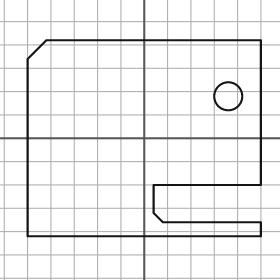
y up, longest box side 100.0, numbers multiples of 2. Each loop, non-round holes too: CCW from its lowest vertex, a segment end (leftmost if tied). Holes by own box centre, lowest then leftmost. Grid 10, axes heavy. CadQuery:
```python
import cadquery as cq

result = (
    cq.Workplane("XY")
    .moveTo(-50.0, -42.0)
    .lineTo(50.0, -42.0)
    .lineTo(50.0, -36.0)
    .lineTo(8.0, -36.0)
    .lineTo(4.0, -32.0)
    .lineTo(4.0, -20.0)
    .lineTo(50.0, -20.0)
    .lineTo(50.0, 42.0)
    .lineTo(-42.0, 42.0)
    .lineTo(-50.0, 34.0)
    .close()
    .moveTo(36.0, 18.0)
    .circle(6.0)
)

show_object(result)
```